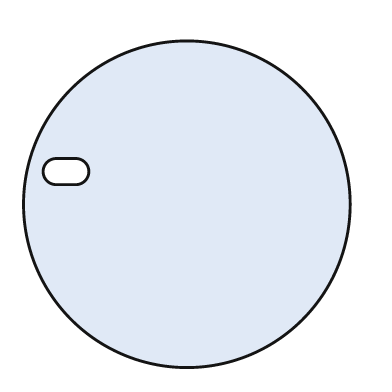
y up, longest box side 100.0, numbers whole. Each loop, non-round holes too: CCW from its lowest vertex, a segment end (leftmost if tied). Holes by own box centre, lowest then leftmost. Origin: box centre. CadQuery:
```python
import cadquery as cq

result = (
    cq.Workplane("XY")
    .moveTo(0.0, 0.0)
    .circle(50.0)
    .moveTo(-40.0, 6.0)
    .lineTo(-34.0, 6.0)
    .threePointArc((-30.0, 10.0), (-34.0, 14.0))
    .lineTo(-40.0, 14.0)
    .threePointArc((-44.0, 10.0), (-40.0, 6.0))
    .close()
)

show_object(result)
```